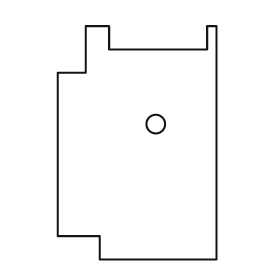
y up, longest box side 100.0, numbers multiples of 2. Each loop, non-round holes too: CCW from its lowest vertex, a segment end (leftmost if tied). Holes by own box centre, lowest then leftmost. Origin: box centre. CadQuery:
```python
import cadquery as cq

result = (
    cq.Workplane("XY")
    .moveTo(-16.0, -50.0)
    .lineTo(34.0, -50.0)
    .lineTo(34.0, 50.0)
    .lineTo(30.0, 50.0)
    .lineTo(30.0, 40.0)
    .lineTo(-12.0, 40.0)
    .lineTo(-12.0, 50.0)
    .lineTo(-22.0, 50.0)
    .lineTo(-22.0, 30.0)
    .lineTo(-34.0, 30.0)
    .lineTo(-34.0, -40.0)
    .lineTo(-16.0, -40.0)
    .close()
    .moveTo(8.0, 8.0)
    .circle(4.0)
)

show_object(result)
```